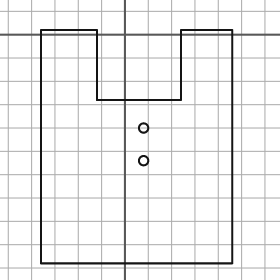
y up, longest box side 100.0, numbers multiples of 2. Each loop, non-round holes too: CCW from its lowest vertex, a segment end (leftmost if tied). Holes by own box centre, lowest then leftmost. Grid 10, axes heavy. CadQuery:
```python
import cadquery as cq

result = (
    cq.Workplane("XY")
    .moveTo(-36.0, -98.0)
    .lineTo(46.0, -98.0)
    .lineTo(46.0, 2.0)
    .lineTo(24.0, 2.0)
    .lineTo(24.0, -28.0)
    .lineTo(-12.0, -28.0)
    .lineTo(-12.0, 2.0)
    .lineTo(-36.0, 2.0)
    .close()
    .moveTo(8.0, -54.0)
    .circle(2.0)
    .moveTo(8.0, -40.0)
    .circle(2.0)
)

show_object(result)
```